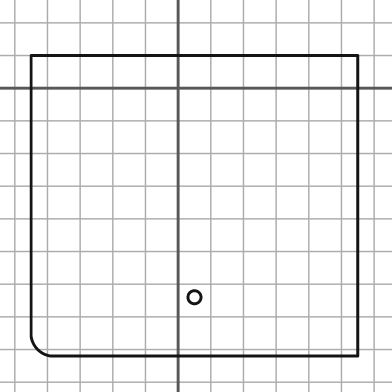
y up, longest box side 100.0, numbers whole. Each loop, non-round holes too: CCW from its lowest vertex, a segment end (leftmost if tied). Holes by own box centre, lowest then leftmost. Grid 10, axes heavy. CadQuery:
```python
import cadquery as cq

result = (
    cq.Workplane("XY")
    .moveTo(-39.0, -82.0)
    .lineTo(55.0, -82.0)
    .lineTo(55.0, 10.0)
    .lineTo(-45.0, 10.0)
    .lineTo(-45.0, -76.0)
    .threePointArc((-43.0, -80.0), (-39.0, -82.0))
    .close()
    .moveTo(5.0, -64.0)
    .circle(2.0)
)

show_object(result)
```